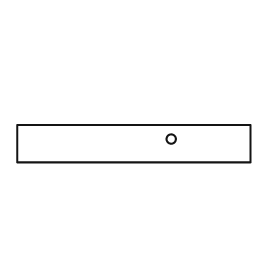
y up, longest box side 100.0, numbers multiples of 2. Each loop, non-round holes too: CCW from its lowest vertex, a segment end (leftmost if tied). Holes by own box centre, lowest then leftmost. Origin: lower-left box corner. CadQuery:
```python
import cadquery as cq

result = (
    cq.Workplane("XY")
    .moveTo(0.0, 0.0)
    .lineTo(100.0, 0.0)
    .lineTo(100.0, 16.0)
    .lineTo(0.0, 16.0)
    .close()
    .moveTo(66.0, 10.0)
    .circle(2.0)
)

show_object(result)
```